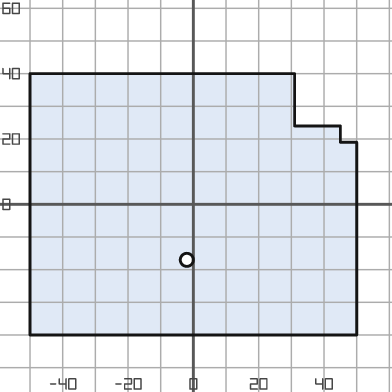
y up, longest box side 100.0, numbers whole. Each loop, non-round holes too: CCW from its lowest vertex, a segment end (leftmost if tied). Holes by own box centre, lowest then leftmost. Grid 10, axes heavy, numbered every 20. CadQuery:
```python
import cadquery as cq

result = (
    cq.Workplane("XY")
    .moveTo(-50.0, -40.0)
    .lineTo(50.0, -40.0)
    .lineTo(50.0, 19.0)
    .lineTo(45.0, 19.0)
    .lineTo(45.0, 24.0)
    .lineTo(31.0, 24.0)
    .lineTo(31.0, 40.0)
    .lineTo(-50.0, 40.0)
    .close()
    .moveTo(-2.0, -17.0)
    .circle(2.0)
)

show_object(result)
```